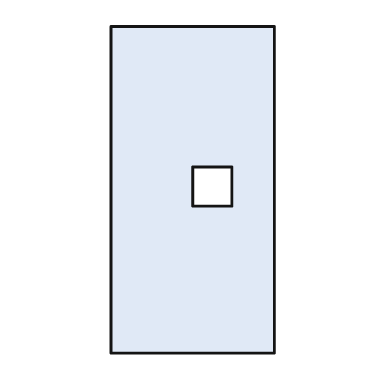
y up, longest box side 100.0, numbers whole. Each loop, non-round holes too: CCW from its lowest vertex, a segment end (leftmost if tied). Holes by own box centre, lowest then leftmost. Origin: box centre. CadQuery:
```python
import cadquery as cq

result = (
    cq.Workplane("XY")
    .moveTo(-25.0, -50.0)
    .lineTo(25.0, -50.0)
    .lineTo(25.0, 50.0)
    .lineTo(-25.0, 50.0)
    .close()
    .moveTo(0.0, -5.0)
    .lineTo(12.0, -5.0)
    .lineTo(12.0, 7.0)
    .lineTo(0.0, 7.0)
    .close()
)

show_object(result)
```